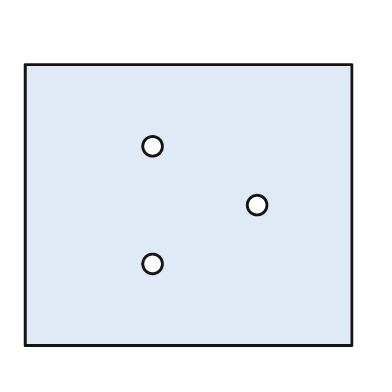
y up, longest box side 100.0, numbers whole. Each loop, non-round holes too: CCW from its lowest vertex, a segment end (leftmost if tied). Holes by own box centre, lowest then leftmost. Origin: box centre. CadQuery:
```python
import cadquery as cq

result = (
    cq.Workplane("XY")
    .moveTo(-50.0, -43.0)
    .lineTo(50.0, -43.0)
    .lineTo(50.0, 43.0)
    .lineTo(-50.0, 43.0)
    .close()
    .moveTo(-11.0, -18.0)
    .circle(3.0)
    .moveTo(21.0, 0.0)
    .circle(3.0)
    .moveTo(-11.0, 18.0)
    .circle(3.0)
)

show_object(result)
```